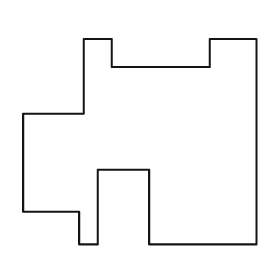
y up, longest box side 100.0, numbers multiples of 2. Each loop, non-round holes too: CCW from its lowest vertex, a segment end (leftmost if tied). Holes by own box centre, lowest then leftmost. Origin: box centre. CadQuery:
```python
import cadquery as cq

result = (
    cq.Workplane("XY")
    .moveTo(-26.0, -44.0)
    .lineTo(-18.0, -44.0)
    .lineTo(-18.0, -12.0)
    .lineTo(4.0, -12.0)
    .lineTo(4.0, -44.0)
    .lineTo(50.0, -44.0)
    .lineTo(50.0, 44.0)
    .lineTo(30.0, 44.0)
    .lineTo(30.0, 32.0)
    .lineTo(-12.0, 32.0)
    .lineTo(-12.0, 44.0)
    .lineTo(-24.0, 44.0)
    .lineTo(-24.0, 12.0)
    .lineTo(-50.0, 12.0)
    .lineTo(-50.0, -30.0)
    .lineTo(-26.0, -30.0)
    .close()
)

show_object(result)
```